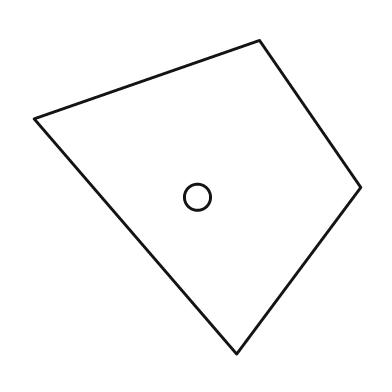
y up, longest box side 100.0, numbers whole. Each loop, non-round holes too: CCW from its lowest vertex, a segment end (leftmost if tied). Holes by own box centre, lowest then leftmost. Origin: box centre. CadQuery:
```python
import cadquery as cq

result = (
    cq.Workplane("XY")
    .moveTo(12.0, -48.0)
    .lineTo(50.0, 3.0)
    .lineTo(19.0, 48.0)
    .lineTo(-50.0, 24.0)
    .close()
    .moveTo(0.0, 0.0)
    .circle(4.0)
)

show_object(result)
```